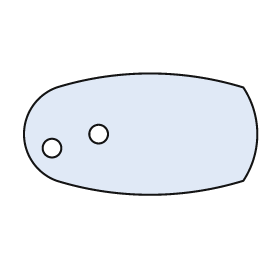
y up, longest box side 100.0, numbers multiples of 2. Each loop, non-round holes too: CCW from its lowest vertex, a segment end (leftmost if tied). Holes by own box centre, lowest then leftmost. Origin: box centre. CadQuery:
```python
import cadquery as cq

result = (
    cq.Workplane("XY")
    .moveTo(-36.0, -20.0)
    .threePointArc((4.0, -26.0), (44.0, -20.0))
    .threePointArc((50.0, 0.0), (44.0, 20.0))
    .threePointArc((4.0, 26.0), (-36.0, 20.0))
    .threePointArc((-50.0, 0.0), (-36.0, -20.0))
    .close()
    .moveTo(-38.0, -6.0)
    .circle(4.0)
    .moveTo(-18.0, 0.0)
    .circle(4.0)
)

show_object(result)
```